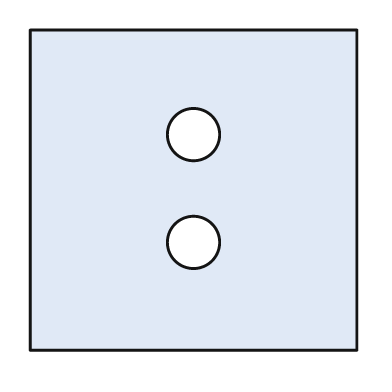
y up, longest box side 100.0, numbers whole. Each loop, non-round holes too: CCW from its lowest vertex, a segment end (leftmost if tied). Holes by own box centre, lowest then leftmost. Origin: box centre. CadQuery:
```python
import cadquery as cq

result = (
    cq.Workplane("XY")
    .moveTo(-50.0, -49.0)
    .lineTo(50.0, -49.0)
    .lineTo(50.0, 49.0)
    .lineTo(-50.0, 49.0)
    .close()
    .moveTo(0.0, -16.0)
    .circle(8.0)
    .moveTo(0.0, 17.0)
    .circle(8.0)
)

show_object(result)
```